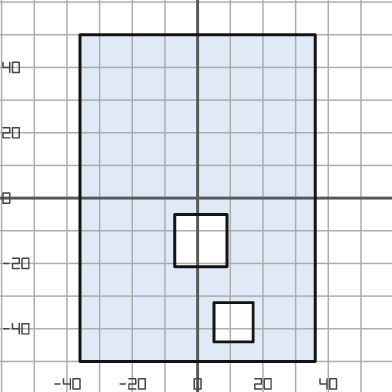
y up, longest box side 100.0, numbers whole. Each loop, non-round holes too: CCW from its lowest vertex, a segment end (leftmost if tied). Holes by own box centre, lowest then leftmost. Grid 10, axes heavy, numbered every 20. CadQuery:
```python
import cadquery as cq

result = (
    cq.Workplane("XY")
    .moveTo(-36.0, -50.0)
    .lineTo(36.0, -50.0)
    .lineTo(36.0, 50.0)
    .lineTo(-36.0, 50.0)
    .close()
    .moveTo(5.0, -44.0)
    .lineTo(17.0, -44.0)
    .lineTo(17.0, -32.0)
    .lineTo(5.0, -32.0)
    .close()
    .moveTo(-7.0, -21.0)
    .lineTo(9.0, -21.0)
    .lineTo(9.0, -5.0)
    .lineTo(-7.0, -5.0)
    .close()
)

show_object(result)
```